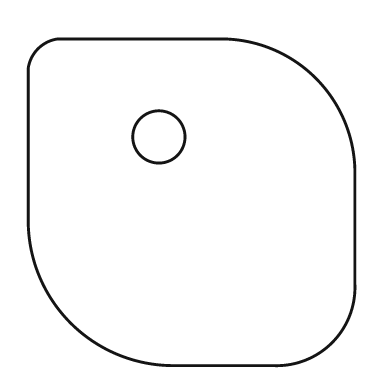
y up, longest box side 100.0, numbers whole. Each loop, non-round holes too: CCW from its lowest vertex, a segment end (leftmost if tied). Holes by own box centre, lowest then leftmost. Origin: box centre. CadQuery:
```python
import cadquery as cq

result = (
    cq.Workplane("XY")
    .moveTo(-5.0, -50.0)
    .lineTo(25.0, -50.0)
    .threePointArc((43.0, -43.0), (50.0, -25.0))
    .lineTo(50.0, 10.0)
    .threePointArc((38.0, 38.0), (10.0, 50.0))
    .lineTo(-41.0, 50.0)
    .threePointArc((-47.0, 47.0), (-50.0, 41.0))
    .lineTo(-50.0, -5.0)
    .threePointArc((-37.0, -37.0), (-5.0, -50.0))
    .close()
    .moveTo(-10.0, 20.0)
    .circle(8.0)
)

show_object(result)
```